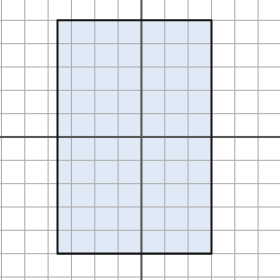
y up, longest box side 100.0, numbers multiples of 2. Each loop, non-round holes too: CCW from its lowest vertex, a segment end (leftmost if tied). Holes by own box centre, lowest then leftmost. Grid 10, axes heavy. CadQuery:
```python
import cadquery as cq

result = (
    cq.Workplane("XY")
    .moveTo(-36.0, -50.0)
    .lineTo(30.0, -50.0)
    .lineTo(30.0, 50.0)
    .lineTo(-36.0, 50.0)
    .close()
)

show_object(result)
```